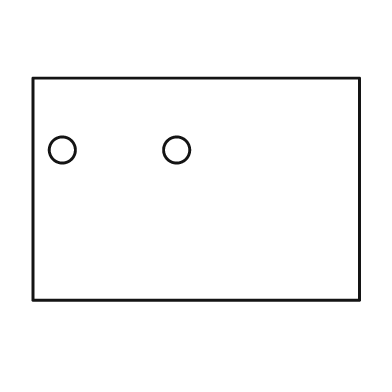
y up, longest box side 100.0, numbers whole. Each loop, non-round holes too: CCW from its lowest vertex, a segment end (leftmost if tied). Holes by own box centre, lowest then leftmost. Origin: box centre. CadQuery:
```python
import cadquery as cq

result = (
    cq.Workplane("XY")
    .moveTo(-50.0, -34.0)
    .lineTo(50.0, -34.0)
    .lineTo(50.0, 34.0)
    .lineTo(-50.0, 34.0)
    .close()
    .moveTo(-41.0, 12.0)
    .circle(4.0)
    .moveTo(-6.0, 12.0)
    .circle(4.0)
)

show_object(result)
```